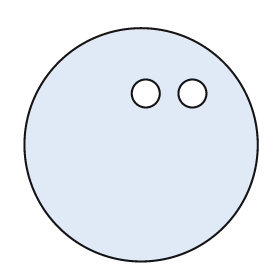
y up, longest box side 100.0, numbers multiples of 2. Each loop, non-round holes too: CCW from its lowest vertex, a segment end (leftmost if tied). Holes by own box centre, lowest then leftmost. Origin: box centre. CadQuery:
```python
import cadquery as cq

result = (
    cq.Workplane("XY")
    .moveTo(0.0, 0.0)
    .circle(50.0)
    .moveTo(2.0, 22.0)
    .circle(6.0)
    .moveTo(22.0, 22.0)
    .circle(6.0)
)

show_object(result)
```